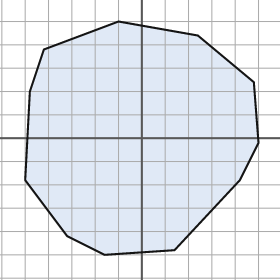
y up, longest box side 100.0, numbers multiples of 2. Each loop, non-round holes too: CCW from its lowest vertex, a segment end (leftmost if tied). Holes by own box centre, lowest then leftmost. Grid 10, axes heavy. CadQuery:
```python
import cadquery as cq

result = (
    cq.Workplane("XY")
    .moveTo(-16.0, -50.0)
    .lineTo(14.0, -48.0)
    .lineTo(42.0, -18.0)
    .lineTo(50.0, -2.0)
    .lineTo(48.0, 24.0)
    .lineTo(24.0, 44.0)
    .lineTo(-10.0, 50.0)
    .lineTo(-42.0, 38.0)
    .lineTo(-48.0, 20.0)
    .lineTo(-50.0, -18.0)
    .lineTo(-32.0, -42.0)
    .close()
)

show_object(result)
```